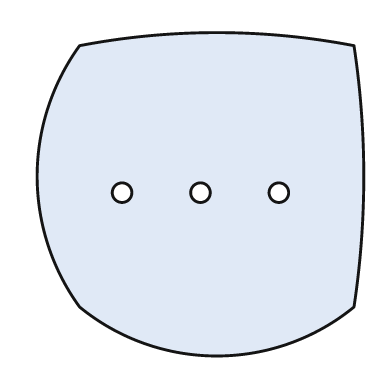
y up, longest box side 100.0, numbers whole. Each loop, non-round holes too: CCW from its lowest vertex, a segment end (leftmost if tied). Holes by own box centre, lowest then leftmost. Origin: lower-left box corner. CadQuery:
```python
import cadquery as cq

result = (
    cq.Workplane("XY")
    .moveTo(13.0, 15.0)
    .threePointArc((55.0, 0.0), (97.0, 15.0))
    .threePointArc((100.0, 55.0), (97.0, 95.0))
    .threePointArc((55.0, 99.0), (13.0, 95.0))
    .threePointArc((0.0, 55.0), (13.0, 15.0))
    .close()
    .moveTo(26.0, 50.0)
    .circle(3.0)
    .moveTo(50.0, 50.0)
    .circle(3.0)
    .moveTo(74.0, 50.0)
    .circle(3.0)
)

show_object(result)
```